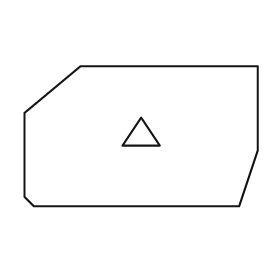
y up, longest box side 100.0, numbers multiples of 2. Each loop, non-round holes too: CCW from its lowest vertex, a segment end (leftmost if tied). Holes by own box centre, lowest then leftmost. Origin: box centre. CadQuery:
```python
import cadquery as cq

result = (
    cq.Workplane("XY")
    .moveTo(-46.0, -30.0)
    .lineTo(42.0, -30.0)
    .lineTo(50.0, -6.0)
    .lineTo(50.0, 30.0)
    .lineTo(-26.0, 30.0)
    .lineTo(-50.0, 10.0)
    .lineTo(-50.0, -26.0)
    .close()
    .moveTo(-8.0, -4.0)
    .lineTo(8.0, -4.0)
    .lineTo(0.0, 8.0)
    .close()
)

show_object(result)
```